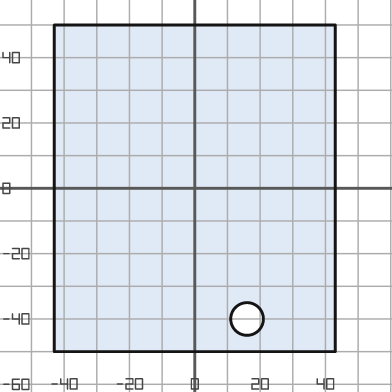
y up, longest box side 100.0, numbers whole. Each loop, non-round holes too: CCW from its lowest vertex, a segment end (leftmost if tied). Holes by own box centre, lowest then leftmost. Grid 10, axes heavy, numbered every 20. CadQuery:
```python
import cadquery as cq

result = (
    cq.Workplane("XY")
    .moveTo(-43.0, -50.0)
    .lineTo(43.0, -50.0)
    .lineTo(43.0, 50.0)
    .lineTo(-43.0, 50.0)
    .close()
    .moveTo(16.0, -40.0)
    .circle(5.0)
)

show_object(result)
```